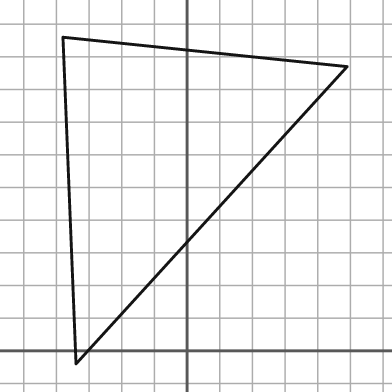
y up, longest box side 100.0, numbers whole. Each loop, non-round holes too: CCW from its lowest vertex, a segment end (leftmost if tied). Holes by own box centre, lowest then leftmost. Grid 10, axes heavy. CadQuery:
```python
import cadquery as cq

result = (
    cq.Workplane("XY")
    .moveTo(-34.0, -4.0)
    .lineTo(49.0, 87.0)
    .lineTo(-38.0, 96.0)
    .close()
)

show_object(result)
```